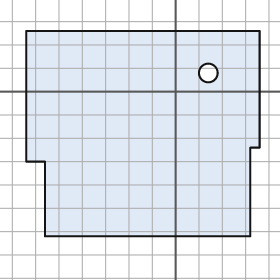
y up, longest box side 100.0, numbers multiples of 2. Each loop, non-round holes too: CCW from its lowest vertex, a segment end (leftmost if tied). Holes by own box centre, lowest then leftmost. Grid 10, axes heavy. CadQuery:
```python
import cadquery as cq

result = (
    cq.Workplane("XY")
    .moveTo(-56.0, -62.0)
    .lineTo(32.0, -62.0)
    .lineTo(32.0, -24.0)
    .lineTo(36.0, -24.0)
    .lineTo(36.0, 26.0)
    .lineTo(-64.0, 26.0)
    .lineTo(-64.0, -30.0)
    .lineTo(-56.0, -30.0)
    .close()
    .moveTo(14.0, 8.0)
    .circle(4.0)
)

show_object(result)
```